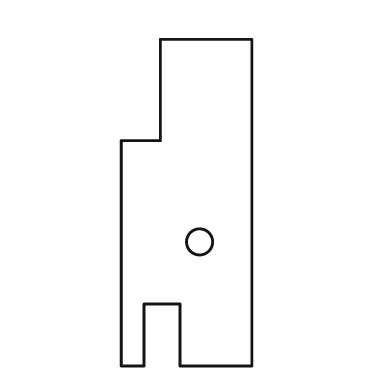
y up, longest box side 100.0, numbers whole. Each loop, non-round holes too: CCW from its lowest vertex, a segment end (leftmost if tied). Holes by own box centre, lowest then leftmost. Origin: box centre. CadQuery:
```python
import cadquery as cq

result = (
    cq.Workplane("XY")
    .moveTo(-20.0, -50.0)
    .lineTo(-13.0, -50.0)
    .lineTo(-13.0, -31.0)
    .lineTo(-2.0, -31.0)
    .lineTo(-2.0, -50.0)
    .lineTo(20.0, -50.0)
    .lineTo(20.0, 50.0)
    .lineTo(-8.0, 50.0)
    .lineTo(-8.0, 19.0)
    .lineTo(-20.0, 19.0)
    .close()
    .moveTo(4.0, -12.0)
    .circle(4.0)
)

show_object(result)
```